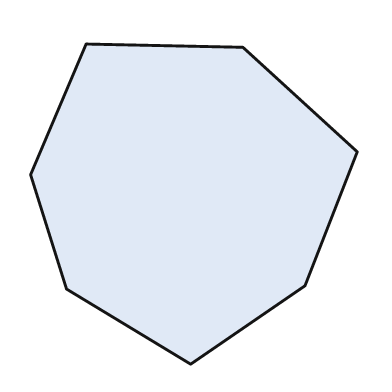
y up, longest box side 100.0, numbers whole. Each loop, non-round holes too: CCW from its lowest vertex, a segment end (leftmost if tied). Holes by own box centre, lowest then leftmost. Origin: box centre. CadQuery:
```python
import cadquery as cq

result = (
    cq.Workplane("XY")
    .moveTo(-1.0, -49.0)
    .lineTo(34.0, -25.0)
    .lineTo(50.0, 16.0)
    .lineTo(15.0, 48.0)
    .lineTo(-33.0, 49.0)
    .lineTo(-50.0, 9.0)
    .lineTo(-39.0, -26.0)
    .close()
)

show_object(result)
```